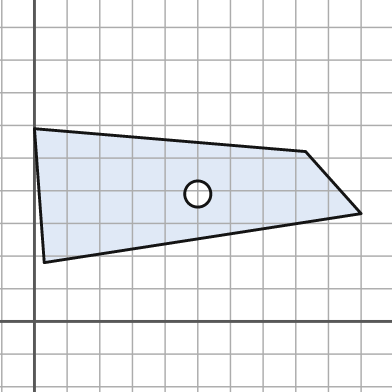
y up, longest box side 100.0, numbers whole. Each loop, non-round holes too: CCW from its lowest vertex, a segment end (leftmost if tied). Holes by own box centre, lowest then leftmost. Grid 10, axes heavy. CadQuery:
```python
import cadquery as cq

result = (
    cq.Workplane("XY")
    .moveTo(3.0, 18.0)
    .lineTo(100.0, 33.0)
    .lineTo(83.0, 52.0)
    .lineTo(0.0, 59.0)
    .close()
    .moveTo(50.0, 39.0)
    .circle(4.0)
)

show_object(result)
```